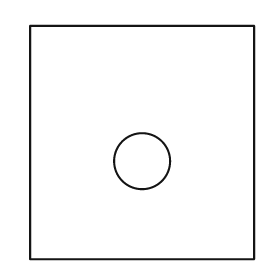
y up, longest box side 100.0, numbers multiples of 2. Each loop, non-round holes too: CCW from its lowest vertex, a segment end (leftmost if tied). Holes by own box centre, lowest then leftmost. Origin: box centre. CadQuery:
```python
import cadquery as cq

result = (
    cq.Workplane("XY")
    .moveTo(-48.0, -50.0)
    .lineTo(48.0, -50.0)
    .lineTo(48.0, 50.0)
    .lineTo(-48.0, 50.0)
    .close()
    .moveTo(0.0, -8.0)
    .circle(12.0)
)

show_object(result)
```